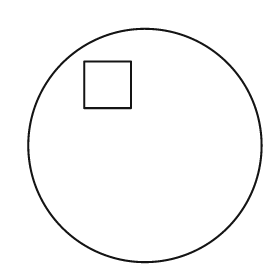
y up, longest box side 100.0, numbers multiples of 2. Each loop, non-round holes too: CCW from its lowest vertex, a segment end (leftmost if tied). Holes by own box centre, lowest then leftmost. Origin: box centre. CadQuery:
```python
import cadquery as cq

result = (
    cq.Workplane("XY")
    .moveTo(0.0, 0.0)
    .circle(50.0)
    .moveTo(-26.0, 16.0)
    .lineTo(-6.0, 16.0)
    .lineTo(-6.0, 36.0)
    .lineTo(-26.0, 36.0)
    .close()
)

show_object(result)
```